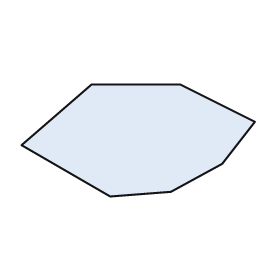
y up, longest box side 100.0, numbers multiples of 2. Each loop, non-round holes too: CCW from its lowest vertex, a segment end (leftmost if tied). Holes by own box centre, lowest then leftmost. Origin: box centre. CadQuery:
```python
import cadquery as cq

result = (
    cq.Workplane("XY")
    .moveTo(-12.0, -24.0)
    .lineTo(14.0, -22.0)
    .lineTo(36.0, -10.0)
    .lineTo(50.0, 8.0)
    .lineTo(18.0, 24.0)
    .lineTo(-20.0, 24.0)
    .lineTo(-50.0, -2.0)
    .close()
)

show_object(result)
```